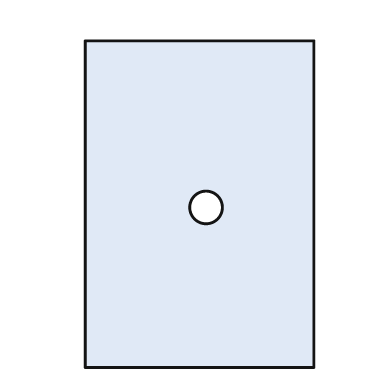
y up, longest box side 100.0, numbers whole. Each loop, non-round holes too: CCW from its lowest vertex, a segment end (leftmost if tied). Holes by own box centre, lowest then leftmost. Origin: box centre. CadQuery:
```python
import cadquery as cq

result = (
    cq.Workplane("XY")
    .moveTo(-35.0, -50.0)
    .lineTo(35.0, -50.0)
    .lineTo(35.0, 50.0)
    .lineTo(-35.0, 50.0)
    .close()
    .moveTo(2.0, -1.0)
    .circle(5.0)
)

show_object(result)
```